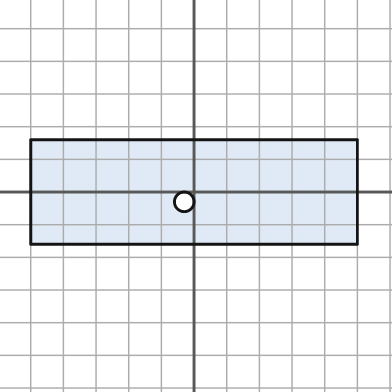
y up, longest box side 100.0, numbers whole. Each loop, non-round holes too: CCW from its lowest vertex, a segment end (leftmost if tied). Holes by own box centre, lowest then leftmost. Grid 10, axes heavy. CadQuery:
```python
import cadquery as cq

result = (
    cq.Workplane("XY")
    .moveTo(-50.0, -16.0)
    .lineTo(50.0, -16.0)
    .lineTo(50.0, 16.0)
    .lineTo(-50.0, 16.0)
    .close()
    .moveTo(-3.0, -3.0)
    .circle(3.0)
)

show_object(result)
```